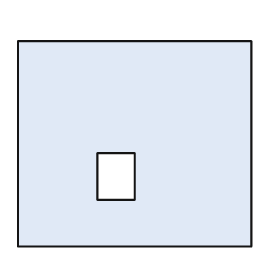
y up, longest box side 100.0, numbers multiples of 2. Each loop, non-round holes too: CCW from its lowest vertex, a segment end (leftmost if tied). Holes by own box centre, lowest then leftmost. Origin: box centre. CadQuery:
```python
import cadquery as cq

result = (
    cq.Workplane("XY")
    .moveTo(-50.0, -44.0)
    .lineTo(50.0, -44.0)
    .lineTo(50.0, 44.0)
    .lineTo(-50.0, 44.0)
    .close()
    .moveTo(-16.0, -24.0)
    .lineTo(0.0, -24.0)
    .lineTo(0.0, -4.0)
    .lineTo(-16.0, -4.0)
    .close()
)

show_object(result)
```